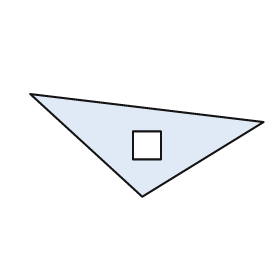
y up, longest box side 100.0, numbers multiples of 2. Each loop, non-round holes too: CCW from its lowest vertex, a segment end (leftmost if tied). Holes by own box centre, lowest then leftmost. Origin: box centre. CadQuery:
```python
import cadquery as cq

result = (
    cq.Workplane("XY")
    .moveTo(-2.0, -22.0)
    .lineTo(50.0, 10.0)
    .lineTo(-50.0, 22.0)
    .close()
    .moveTo(-6.0, -6.0)
    .lineTo(6.0, -6.0)
    .lineTo(6.0, 6.0)
    .lineTo(-6.0, 6.0)
    .close()
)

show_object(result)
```